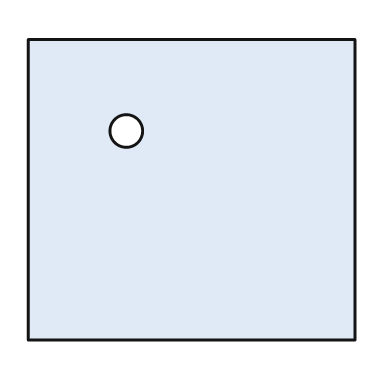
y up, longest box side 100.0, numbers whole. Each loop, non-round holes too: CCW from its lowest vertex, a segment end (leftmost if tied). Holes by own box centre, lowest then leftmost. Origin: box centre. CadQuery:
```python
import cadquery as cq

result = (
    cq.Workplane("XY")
    .moveTo(-50.0, -46.0)
    .lineTo(50.0, -46.0)
    .lineTo(50.0, 46.0)
    .lineTo(-50.0, 46.0)
    .close()
    .moveTo(-20.0, 18.0)
    .circle(5.0)
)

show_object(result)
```